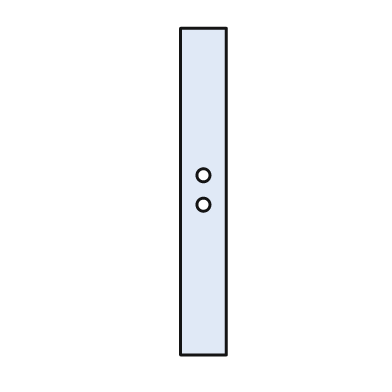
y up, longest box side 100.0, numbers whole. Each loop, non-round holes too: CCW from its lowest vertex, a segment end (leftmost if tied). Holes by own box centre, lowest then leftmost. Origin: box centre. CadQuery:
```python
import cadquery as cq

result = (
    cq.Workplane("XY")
    .moveTo(-7.0, -50.0)
    .lineTo(7.0, -50.0)
    .lineTo(7.0, 50.0)
    .lineTo(-7.0, 50.0)
    .close()
    .moveTo(0.0, -4.0)
    .circle(2.0)
    .moveTo(0.0, 5.0)
    .circle(2.0)
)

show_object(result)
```